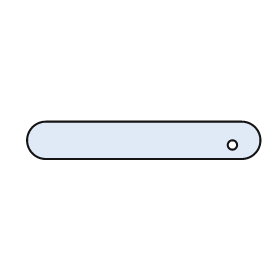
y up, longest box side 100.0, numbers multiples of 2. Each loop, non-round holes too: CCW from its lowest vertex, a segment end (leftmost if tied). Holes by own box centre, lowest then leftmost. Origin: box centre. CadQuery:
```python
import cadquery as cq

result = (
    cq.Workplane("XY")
    .moveTo(-42.0, -8.0)
    .lineTo(42.0, -8.0)
    .threePointArc((50.0, 0.0), (42.0, 8.0))
    .lineTo(-42.0, 8.0)
    .threePointArc((-50.0, 0.0), (-42.0, -8.0))
    .close()
    .moveTo(38.0, -2.0)
    .circle(2.0)
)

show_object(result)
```